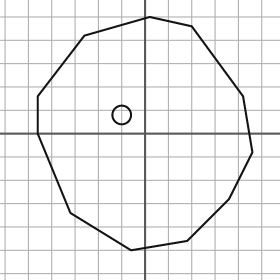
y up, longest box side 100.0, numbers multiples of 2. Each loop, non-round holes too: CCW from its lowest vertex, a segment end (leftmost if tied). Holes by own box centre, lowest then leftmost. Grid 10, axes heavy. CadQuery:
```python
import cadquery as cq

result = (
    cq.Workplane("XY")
    .moveTo(-6.0, -50.0)
    .lineTo(18.0, -46.0)
    .lineTo(36.0, -28.0)
    .lineTo(46.0, -8.0)
    .lineTo(42.0, 16.0)
    .lineTo(20.0, 46.0)
    .lineTo(2.0, 50.0)
    .lineTo(-26.0, 42.0)
    .lineTo(-46.0, 16.0)
    .lineTo(-46.0, 0.0)
    .lineTo(-32.0, -34.0)
    .close()
    .moveTo(-10.0, 8.0)
    .circle(4.0)
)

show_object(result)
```